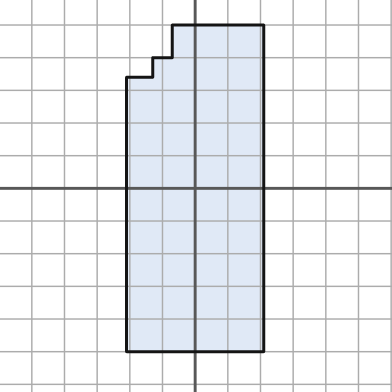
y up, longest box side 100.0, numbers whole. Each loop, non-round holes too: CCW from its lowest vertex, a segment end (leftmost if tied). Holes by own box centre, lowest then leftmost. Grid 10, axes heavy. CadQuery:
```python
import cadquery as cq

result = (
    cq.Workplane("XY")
    .moveTo(-21.0, -50.0)
    .lineTo(21.0, -50.0)
    .lineTo(21.0, 50.0)
    .lineTo(-7.0, 50.0)
    .lineTo(-7.0, 40.0)
    .lineTo(-13.0, 40.0)
    .lineTo(-13.0, 34.0)
    .lineTo(-21.0, 34.0)
    .close()
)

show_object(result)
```